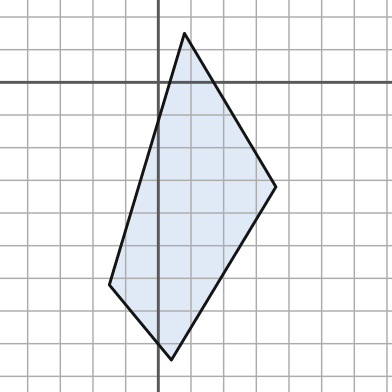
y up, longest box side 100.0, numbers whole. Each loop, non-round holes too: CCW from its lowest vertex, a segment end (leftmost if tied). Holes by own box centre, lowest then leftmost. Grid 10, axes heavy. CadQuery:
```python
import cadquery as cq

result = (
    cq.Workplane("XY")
    .moveTo(4.0, -85.0)
    .lineTo(36.0, -32.0)
    .lineTo(8.0, 15.0)
    .lineTo(-15.0, -62.0)
    .close()
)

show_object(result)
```